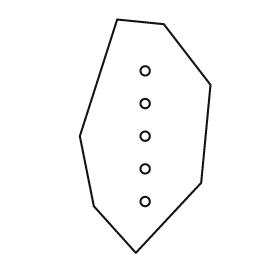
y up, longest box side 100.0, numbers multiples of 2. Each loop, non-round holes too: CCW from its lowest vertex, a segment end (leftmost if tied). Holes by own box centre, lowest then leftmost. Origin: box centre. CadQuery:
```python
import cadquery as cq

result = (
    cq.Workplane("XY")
    .moveTo(-4.0, -50.0)
    .lineTo(24.0, -20.0)
    .lineTo(28.0, 22.0)
    .lineTo(8.0, 48.0)
    .lineTo(-12.0, 50.0)
    .lineTo(-28.0, 0.0)
    .lineTo(-22.0, -30.0)
    .close()
    .moveTo(0.0, -28.0)
    .circle(2.0)
    .moveTo(0.0, -14.0)
    .circle(2.0)
    .moveTo(0.0, 0.0)
    .circle(2.0)
    .moveTo(0.0, 14.0)
    .circle(2.0)
    .moveTo(0.0, 28.0)
    .circle(2.0)
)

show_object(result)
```